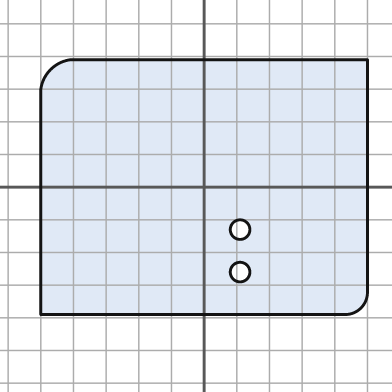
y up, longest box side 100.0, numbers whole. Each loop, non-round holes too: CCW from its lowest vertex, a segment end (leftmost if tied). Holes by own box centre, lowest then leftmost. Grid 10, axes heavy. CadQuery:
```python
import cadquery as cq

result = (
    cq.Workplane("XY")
    .moveTo(-50.0, -39.0)
    .lineTo(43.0, -39.0)
    .threePointArc((48.0, -37.0), (50.0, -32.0))
    .lineTo(50.0, 39.0)
    .lineTo(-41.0, 39.0)
    .threePointArc((-47.0, 36.0), (-50.0, 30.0))
    .close()
    .moveTo(11.0, -26.0)
    .circle(3.0)
    .moveTo(11.0, -13.0)
    .circle(3.0)
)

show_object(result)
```